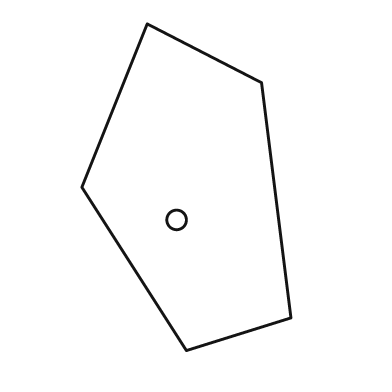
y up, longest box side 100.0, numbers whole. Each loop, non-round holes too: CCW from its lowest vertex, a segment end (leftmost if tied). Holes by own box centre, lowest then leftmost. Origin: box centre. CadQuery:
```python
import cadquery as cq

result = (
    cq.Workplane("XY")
    .moveTo(0.0, -50.0)
    .lineTo(32.0, -40.0)
    .lineTo(23.0, 32.0)
    .lineTo(-12.0, 50.0)
    .lineTo(-32.0, 0.0)
    .close()
    .moveTo(-3.0, -10.0)
    .circle(3.0)
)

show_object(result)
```